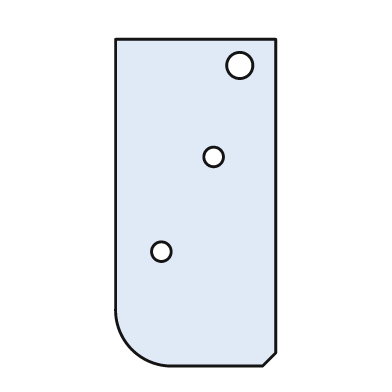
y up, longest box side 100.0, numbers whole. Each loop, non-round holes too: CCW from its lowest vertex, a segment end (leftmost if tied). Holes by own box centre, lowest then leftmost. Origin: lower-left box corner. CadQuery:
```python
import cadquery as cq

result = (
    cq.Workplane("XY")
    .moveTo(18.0, 0.0)
    .lineTo(45.0, 0.0)
    .lineTo(49.0, 4.0)
    .lineTo(49.0, 100.0)
    .lineTo(0.0, 100.0)
    .lineTo(0.0, 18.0)
    .threePointArc((5.0, 5.0), (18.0, 0.0))
    .close()
    .moveTo(14.0, 35.0)
    .circle(3.0)
    .moveTo(30.0, 64.0)
    .circle(3.0)
    .moveTo(38.0, 92.0)
    .circle(4.0)
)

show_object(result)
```